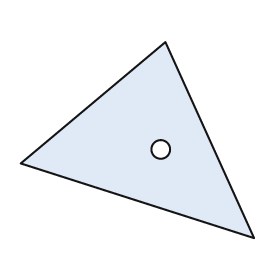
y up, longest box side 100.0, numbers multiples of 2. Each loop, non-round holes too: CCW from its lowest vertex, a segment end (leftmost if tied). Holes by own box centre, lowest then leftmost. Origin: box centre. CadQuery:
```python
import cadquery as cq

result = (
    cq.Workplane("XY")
    .moveTo(50.0, -42.0)
    .lineTo(12.0, 42.0)
    .lineTo(-50.0, -10.0)
    .close()
    .moveTo(10.0, -4.0)
    .circle(4.0)
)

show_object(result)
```